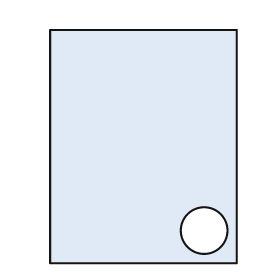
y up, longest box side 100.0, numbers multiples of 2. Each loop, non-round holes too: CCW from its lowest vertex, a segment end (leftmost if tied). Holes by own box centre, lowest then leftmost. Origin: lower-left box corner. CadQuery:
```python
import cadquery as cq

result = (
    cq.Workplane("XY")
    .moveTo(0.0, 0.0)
    .lineTo(80.0, 0.0)
    .lineTo(80.0, 100.0)
    .lineTo(0.0, 100.0)
    .close()
    .moveTo(66.0, 14.0)
    .circle(10.0)
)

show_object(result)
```